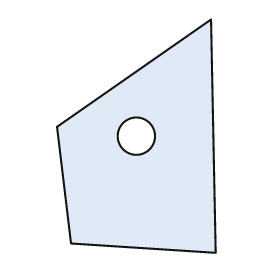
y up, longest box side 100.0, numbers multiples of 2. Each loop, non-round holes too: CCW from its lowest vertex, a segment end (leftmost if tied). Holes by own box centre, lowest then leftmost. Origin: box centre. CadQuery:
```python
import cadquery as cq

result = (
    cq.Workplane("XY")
    .moveTo(34.0, -50.0)
    .lineTo(32.0, 50.0)
    .lineTo(-34.0, 4.0)
    .lineTo(-28.0, -46.0)
    .close()
    .moveTo(0.0, 0.0)
    .circle(8.0)
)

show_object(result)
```